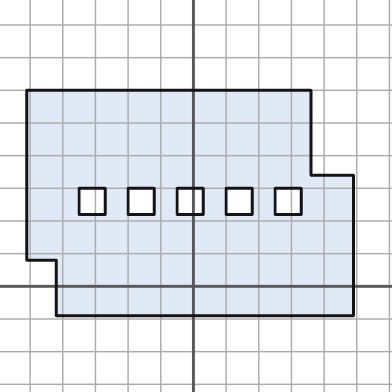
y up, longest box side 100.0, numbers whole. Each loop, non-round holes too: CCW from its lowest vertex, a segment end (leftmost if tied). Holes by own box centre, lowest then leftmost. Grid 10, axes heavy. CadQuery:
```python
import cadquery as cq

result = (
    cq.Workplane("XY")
    .moveTo(-42.0, -9.0)
    .lineTo(49.0, -9.0)
    .lineTo(49.0, 34.0)
    .lineTo(36.0, 34.0)
    .lineTo(36.0, 60.0)
    .lineTo(-51.0, 60.0)
    .lineTo(-51.0, 8.0)
    .lineTo(-42.0, 8.0)
    .close()
    .moveTo(-35.0, 22.0)
    .lineTo(-27.0, 22.0)
    .lineTo(-27.0, 30.0)
    .lineTo(-35.0, 30.0)
    .close()
    .moveTo(-20.0, 22.0)
    .lineTo(-12.0, 22.0)
    .lineTo(-12.0, 30.0)
    .lineTo(-20.0, 30.0)
    .close()
    .moveTo(-5.0, 22.0)
    .lineTo(3.0, 22.0)
    .lineTo(3.0, 30.0)
    .lineTo(-5.0, 30.0)
    .close()
    .moveTo(10.0, 22.0)
    .lineTo(18.0, 22.0)
    .lineTo(18.0, 30.0)
    .lineTo(10.0, 30.0)
    .close()
    .moveTo(25.0, 22.0)
    .lineTo(33.0, 22.0)
    .lineTo(33.0, 30.0)
    .lineTo(25.0, 30.0)
    .close()
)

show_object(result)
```